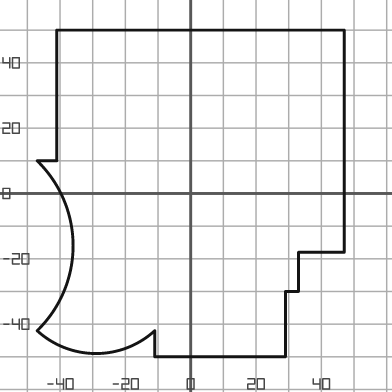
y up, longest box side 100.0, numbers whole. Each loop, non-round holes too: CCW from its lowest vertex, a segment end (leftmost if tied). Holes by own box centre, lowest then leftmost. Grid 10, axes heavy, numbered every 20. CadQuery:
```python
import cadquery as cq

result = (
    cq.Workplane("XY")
    .moveTo(-11.0, -50.0)
    .lineTo(29.0, -50.0)
    .lineTo(29.0, -30.0)
    .lineTo(33.0, -30.0)
    .lineTo(33.0, -18.0)
    .lineTo(47.0, -18.0)
    .lineTo(47.0, 50.0)
    .lineTo(-41.0, 50.0)
    .lineTo(-41.0, 10.0)
    .lineTo(-47.0, 10.0)
    .threePointArc((-36.0, -16.0), (-47.0, -42.0))
    .threePointArc((-29.0, -49.0), (-11.0, -42.0))
    .close()
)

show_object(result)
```